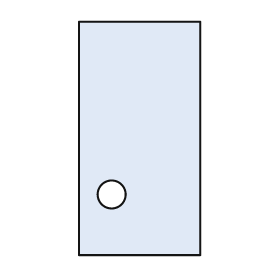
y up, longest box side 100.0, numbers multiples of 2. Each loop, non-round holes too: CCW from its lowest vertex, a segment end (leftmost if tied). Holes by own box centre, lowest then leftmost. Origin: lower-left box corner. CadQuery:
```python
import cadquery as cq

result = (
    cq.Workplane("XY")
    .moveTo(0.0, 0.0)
    .lineTo(52.0, 0.0)
    .lineTo(52.0, 100.0)
    .lineTo(0.0, 100.0)
    .close()
    .moveTo(14.0, 26.0)
    .circle(6.0)
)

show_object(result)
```